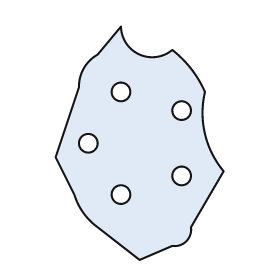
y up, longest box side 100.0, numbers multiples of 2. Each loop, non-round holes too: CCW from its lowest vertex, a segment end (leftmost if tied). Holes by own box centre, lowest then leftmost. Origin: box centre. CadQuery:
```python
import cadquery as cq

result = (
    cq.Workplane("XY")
    .moveTo(0.0, -50.0)
    .lineTo(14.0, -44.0)
    .threePointArc((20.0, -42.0), (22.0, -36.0))
    .lineTo(36.0, -12.0)
    .threePointArc((28.0, 4.0), (28.0, 22.0))
    .threePointArc((22.0, 32.0), (14.0, 40.0))
    .threePointArc((0.0, 38.0), (-8.0, 50.0))
    .lineTo(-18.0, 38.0)
    .threePointArc((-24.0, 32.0), (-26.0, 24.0))
    .lineTo(-36.0, -6.0)
    .lineTo(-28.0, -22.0)
    .threePointArc((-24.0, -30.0), (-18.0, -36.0))
    .close()
    .moveTo(-8.0, -22.0)
    .circle(4.0)
    .moveTo(18.0, -14.0)
    .circle(4.0)
    .moveTo(-22.0, 0.0)
    .circle(4.0)
    .moveTo(18.0, 14.0)
    .circle(4.0)
    .moveTo(-8.0, 22.0)
    .circle(4.0)
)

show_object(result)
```